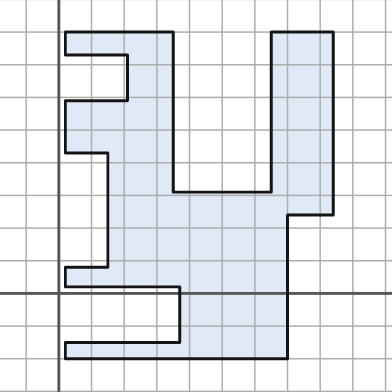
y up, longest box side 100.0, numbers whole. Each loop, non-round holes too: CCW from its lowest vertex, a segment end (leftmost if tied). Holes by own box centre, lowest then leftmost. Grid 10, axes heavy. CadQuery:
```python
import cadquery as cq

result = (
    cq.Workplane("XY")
    .moveTo(2.0, -20.0)
    .lineTo(70.0, -20.0)
    .lineTo(70.0, 24.0)
    .lineTo(84.0, 24.0)
    .lineTo(84.0, 80.0)
    .lineTo(65.0, 80.0)
    .lineTo(65.0, 31.0)
    .lineTo(35.0, 31.0)
    .lineTo(35.0, 80.0)
    .lineTo(2.0, 80.0)
    .lineTo(2.0, 73.0)
    .lineTo(21.0, 73.0)
    .lineTo(21.0, 59.0)
    .lineTo(2.0, 59.0)
    .lineTo(2.0, 43.0)
    .lineTo(15.0, 43.0)
    .lineTo(15.0, 8.0)
    .lineTo(2.0, 8.0)
    .lineTo(2.0, 2.0)
    .lineTo(37.0, 2.0)
    .lineTo(37.0, -15.0)
    .lineTo(2.0, -15.0)
    .close()
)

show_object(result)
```